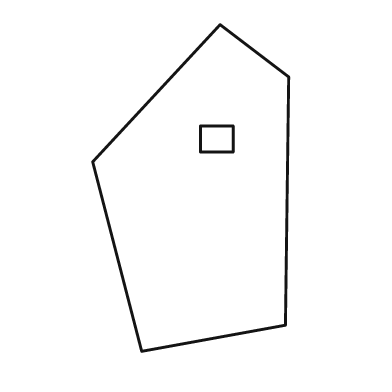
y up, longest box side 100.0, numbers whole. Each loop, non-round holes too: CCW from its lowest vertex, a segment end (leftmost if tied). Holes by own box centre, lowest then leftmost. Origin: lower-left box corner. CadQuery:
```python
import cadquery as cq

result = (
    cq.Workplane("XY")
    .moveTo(15.0, 0.0)
    .lineTo(59.0, 8.0)
    .lineTo(60.0, 84.0)
    .lineTo(39.0, 100.0)
    .lineTo(0.0, 58.0)
    .close()
    .moveTo(33.0, 61.0)
    .lineTo(43.0, 61.0)
    .lineTo(43.0, 69.0)
    .lineTo(33.0, 69.0)
    .close()
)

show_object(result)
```